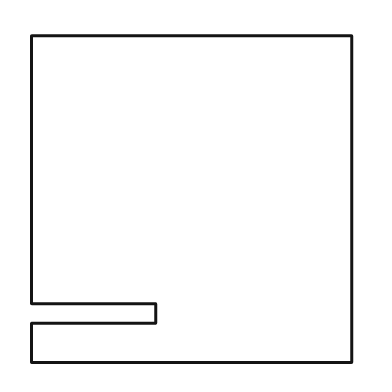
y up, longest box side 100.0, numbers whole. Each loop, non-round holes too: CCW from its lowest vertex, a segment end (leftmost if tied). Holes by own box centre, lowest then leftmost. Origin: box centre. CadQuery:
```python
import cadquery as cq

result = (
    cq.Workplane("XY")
    .moveTo(-49.0, -50.0)
    .lineTo(49.0, -50.0)
    .lineTo(49.0, 50.0)
    .lineTo(-49.0, 50.0)
    .lineTo(-49.0, -32.0)
    .lineTo(-11.0, -32.0)
    .lineTo(-11.0, -38.0)
    .lineTo(-49.0, -38.0)
    .close()
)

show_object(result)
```